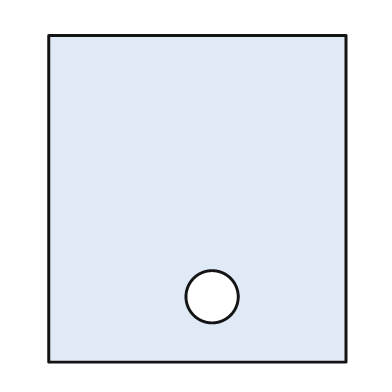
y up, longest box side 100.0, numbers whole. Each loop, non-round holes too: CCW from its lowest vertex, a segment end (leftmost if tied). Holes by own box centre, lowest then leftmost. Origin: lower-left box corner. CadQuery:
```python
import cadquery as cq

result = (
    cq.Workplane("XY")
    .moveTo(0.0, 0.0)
    .lineTo(91.0, 0.0)
    .lineTo(91.0, 100.0)
    .lineTo(0.0, 100.0)
    .close()
    .moveTo(50.0, 20.0)
    .circle(8.0)
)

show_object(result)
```